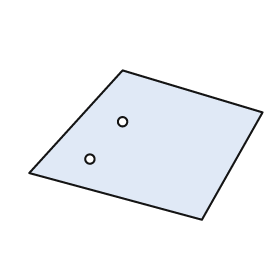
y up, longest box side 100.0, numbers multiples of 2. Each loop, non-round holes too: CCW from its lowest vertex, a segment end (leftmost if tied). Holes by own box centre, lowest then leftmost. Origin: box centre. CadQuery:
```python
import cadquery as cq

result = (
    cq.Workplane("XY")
    .moveTo(24.0, -32.0)
    .lineTo(50.0, 14.0)
    .lineTo(-10.0, 32.0)
    .lineTo(-50.0, -12.0)
    .close()
    .moveTo(-24.0, -6.0)
    .circle(2.0)
    .moveTo(-10.0, 10.0)
    .circle(2.0)
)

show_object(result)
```